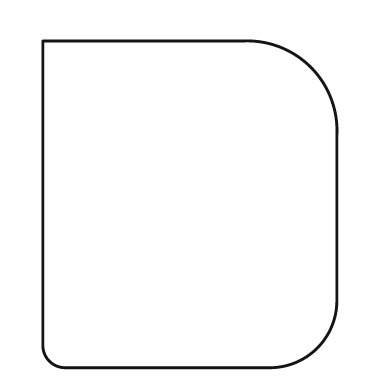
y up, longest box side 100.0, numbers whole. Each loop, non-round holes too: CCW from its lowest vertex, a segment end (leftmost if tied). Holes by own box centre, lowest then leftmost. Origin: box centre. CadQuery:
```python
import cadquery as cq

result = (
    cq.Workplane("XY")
    .moveTo(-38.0, -50.0)
    .lineTo(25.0, -50.0)
    .threePointArc((39.0, -44.0), (45.0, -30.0))
    .lineTo(45.0, 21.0)
    .threePointArc((37.0, 42.0), (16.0, 50.0))
    .lineTo(-45.0, 50.0)
    .lineTo(-45.0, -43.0)
    .threePointArc((-43.0, -48.0), (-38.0, -50.0))
    .close()
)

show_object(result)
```